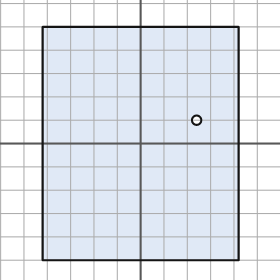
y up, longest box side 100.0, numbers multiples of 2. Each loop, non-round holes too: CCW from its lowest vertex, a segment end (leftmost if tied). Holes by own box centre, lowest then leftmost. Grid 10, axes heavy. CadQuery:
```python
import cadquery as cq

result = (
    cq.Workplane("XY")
    .moveTo(-42.0, -50.0)
    .lineTo(42.0, -50.0)
    .lineTo(42.0, 50.0)
    .lineTo(-42.0, 50.0)
    .close()
    .moveTo(24.0, 10.0)
    .circle(2.0)
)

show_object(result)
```